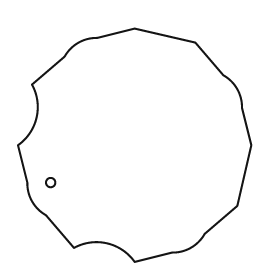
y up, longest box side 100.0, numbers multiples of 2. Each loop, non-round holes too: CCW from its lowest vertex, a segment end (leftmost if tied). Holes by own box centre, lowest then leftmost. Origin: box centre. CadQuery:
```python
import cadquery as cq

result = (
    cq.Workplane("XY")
    .moveTo(0.0, -50.0)
    .lineTo(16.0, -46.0)
    .threePointArc((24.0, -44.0), (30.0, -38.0))
    .lineTo(44.0, -26.0)
    .lineTo(50.0, 0.0)
    .lineTo(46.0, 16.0)
    .threePointArc((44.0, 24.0), (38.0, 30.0))
    .lineTo(26.0, 44.0)
    .lineTo(0.0, 50.0)
    .lineTo(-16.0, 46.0)
    .threePointArc((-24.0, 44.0), (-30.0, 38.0))
    .lineTo(-44.0, 26.0)
    .threePointArc((-42.0, 12.0), (-50.0, 0.0))
    .lineTo(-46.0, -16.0)
    .threePointArc((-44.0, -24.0), (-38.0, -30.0))
    .lineTo(-26.0, -44.0)
    .threePointArc((-12.0, -42.0), (0.0, -50.0))
    .close()
    .moveTo(-36.0, -16.0)
    .circle(2.0)
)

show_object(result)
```